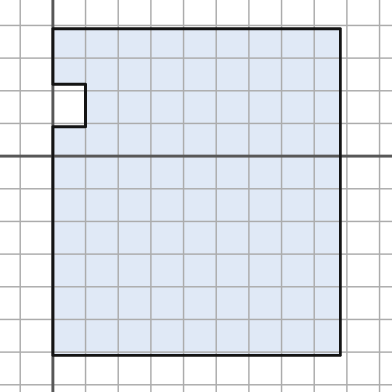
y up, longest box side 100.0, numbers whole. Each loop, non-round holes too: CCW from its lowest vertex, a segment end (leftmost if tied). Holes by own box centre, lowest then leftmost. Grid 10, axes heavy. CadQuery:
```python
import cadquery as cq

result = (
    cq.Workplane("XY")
    .moveTo(0.0, -61.0)
    .lineTo(88.0, -61.0)
    .lineTo(88.0, 39.0)
    .lineTo(0.0, 39.0)
    .lineTo(0.0, 22.0)
    .lineTo(10.0, 22.0)
    .lineTo(10.0, 9.0)
    .lineTo(0.0, 9.0)
    .close()
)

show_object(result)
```